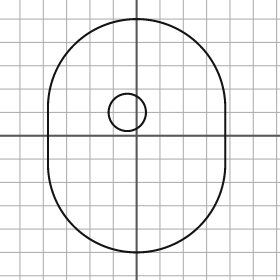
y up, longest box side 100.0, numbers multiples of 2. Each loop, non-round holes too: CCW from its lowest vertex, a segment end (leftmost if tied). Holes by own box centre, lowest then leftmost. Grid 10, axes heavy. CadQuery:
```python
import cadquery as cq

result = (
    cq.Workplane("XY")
    .moveTo(-38.0, -12.0)
    .threePointArc((0.0, -50.0), (38.0, -12.0))
    .lineTo(38.0, 12.0)
    .threePointArc((0.0, 50.0), (-38.0, 12.0))
    .close()
    .moveTo(-4.0, 10.0)
    .circle(8.0)
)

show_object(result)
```